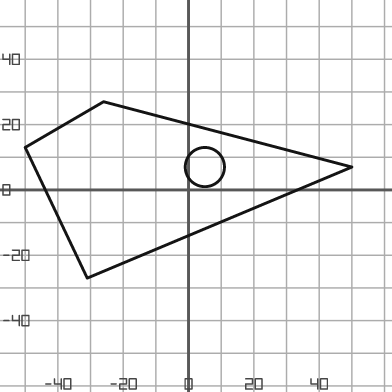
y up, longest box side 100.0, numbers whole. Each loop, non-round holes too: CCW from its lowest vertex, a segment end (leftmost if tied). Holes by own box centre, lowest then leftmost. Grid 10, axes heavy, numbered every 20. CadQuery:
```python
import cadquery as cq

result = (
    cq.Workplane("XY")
    .moveTo(-31.0, -27.0)
    .lineTo(50.0, 7.0)
    .lineTo(-26.0, 27.0)
    .lineTo(-50.0, 13.0)
    .close()
    .moveTo(5.0, 7.0)
    .circle(6.0)
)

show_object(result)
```